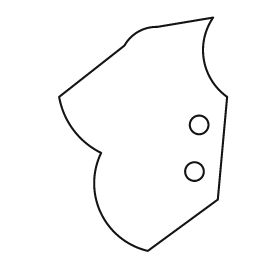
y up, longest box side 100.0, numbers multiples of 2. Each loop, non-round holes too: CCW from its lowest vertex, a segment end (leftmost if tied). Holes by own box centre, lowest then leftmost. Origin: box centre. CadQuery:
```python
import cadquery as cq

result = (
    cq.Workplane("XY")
    .moveTo(2.0, -50.0)
    .lineTo(32.0, -28.0)
    .lineTo(36.0, 16.0)
    .threePointArc((26.0, 32.0), (30.0, 50.0))
    .lineTo(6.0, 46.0)
    .threePointArc((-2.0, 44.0), (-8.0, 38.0))
    .lineTo(-36.0, 16.0)
    .threePointArc((-30.0, 2.0), (-18.0, -8.0))
    .threePointArc((-18.0, -34.0), (2.0, -50.0))
    .close()
    .moveTo(22.0, -16.0)
    .circle(4.0)
    .moveTo(24.0, 4.0)
    .circle(4.0)
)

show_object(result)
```